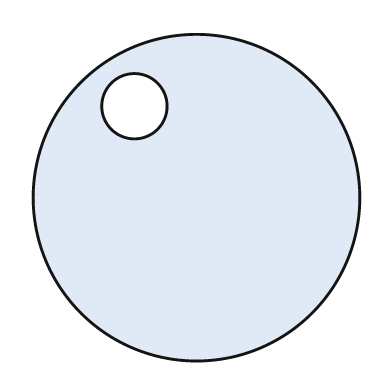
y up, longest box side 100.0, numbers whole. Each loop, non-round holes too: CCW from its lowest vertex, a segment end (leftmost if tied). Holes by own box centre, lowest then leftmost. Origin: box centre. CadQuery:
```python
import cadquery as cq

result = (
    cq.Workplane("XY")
    .moveTo(0.0, 0.0)
    .circle(50.0)
    .moveTo(-19.0, 28.0)
    .circle(10.0)
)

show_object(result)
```